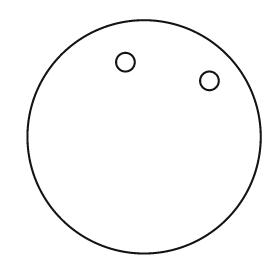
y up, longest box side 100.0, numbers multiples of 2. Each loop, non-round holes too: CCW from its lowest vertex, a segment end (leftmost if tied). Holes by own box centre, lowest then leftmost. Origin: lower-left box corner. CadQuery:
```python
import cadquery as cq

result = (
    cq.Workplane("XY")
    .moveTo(50.0, 50.0)
    .circle(50.0)
    .moveTo(78.0, 74.0)
    .circle(4.0)
    .moveTo(42.0, 82.0)
    .circle(4.0)
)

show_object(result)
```